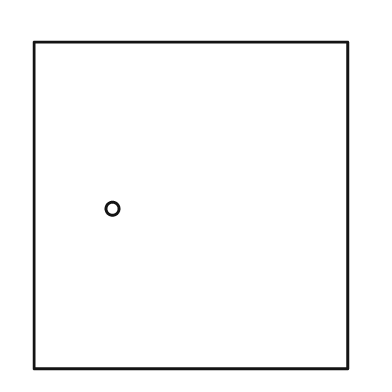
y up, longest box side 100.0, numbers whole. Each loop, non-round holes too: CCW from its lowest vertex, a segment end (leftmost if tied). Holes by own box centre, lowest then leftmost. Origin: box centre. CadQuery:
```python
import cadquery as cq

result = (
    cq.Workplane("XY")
    .moveTo(-48.0, -50.0)
    .lineTo(48.0, -50.0)
    .lineTo(48.0, 50.0)
    .lineTo(-48.0, 50.0)
    .close()
    .moveTo(-24.0, -1.0)
    .circle(2.0)
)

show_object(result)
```